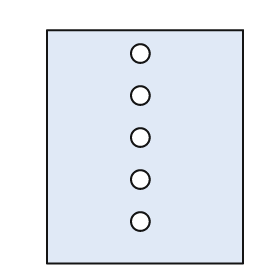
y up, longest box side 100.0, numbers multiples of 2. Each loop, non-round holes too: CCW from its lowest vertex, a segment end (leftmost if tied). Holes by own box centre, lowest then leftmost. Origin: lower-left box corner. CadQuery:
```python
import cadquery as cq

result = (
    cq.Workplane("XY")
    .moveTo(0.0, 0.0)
    .lineTo(84.0, 0.0)
    .lineTo(84.0, 100.0)
    .lineTo(0.0, 100.0)
    .close()
    .moveTo(40.0, 18.0)
    .circle(4.0)
    .moveTo(40.0, 36.0)
    .circle(4.0)
    .moveTo(40.0, 54.0)
    .circle(4.0)
    .moveTo(40.0, 72.0)
    .circle(4.0)
    .moveTo(40.0, 90.0)
    .circle(4.0)
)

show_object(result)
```